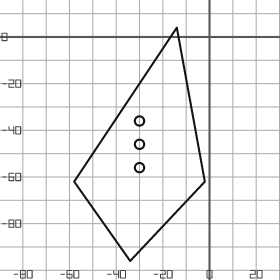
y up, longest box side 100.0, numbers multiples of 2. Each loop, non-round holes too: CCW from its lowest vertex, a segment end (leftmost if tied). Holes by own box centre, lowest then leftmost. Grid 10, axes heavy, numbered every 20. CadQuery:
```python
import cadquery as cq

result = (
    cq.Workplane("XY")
    .moveTo(-34.0, -96.0)
    .lineTo(-2.0, -62.0)
    .lineTo(-14.0, 4.0)
    .lineTo(-58.0, -62.0)
    .close()
    .moveTo(-30.0, -56.0)
    .circle(2.0)
    .moveTo(-30.0, -46.0)
    .circle(2.0)
    .moveTo(-30.0, -36.0)
    .circle(2.0)
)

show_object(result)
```